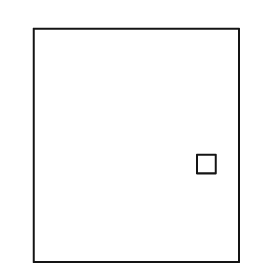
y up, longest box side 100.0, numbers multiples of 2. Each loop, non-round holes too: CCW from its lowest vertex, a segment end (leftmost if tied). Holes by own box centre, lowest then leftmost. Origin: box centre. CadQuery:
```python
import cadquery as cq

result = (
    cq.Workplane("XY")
    .moveTo(-44.0, -50.0)
    .lineTo(44.0, -50.0)
    .lineTo(44.0, 50.0)
    .lineTo(-44.0, 50.0)
    .close()
    .moveTo(26.0, -12.0)
    .lineTo(34.0, -12.0)
    .lineTo(34.0, -4.0)
    .lineTo(26.0, -4.0)
    .close()
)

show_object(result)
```